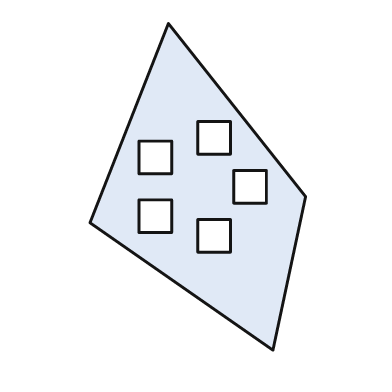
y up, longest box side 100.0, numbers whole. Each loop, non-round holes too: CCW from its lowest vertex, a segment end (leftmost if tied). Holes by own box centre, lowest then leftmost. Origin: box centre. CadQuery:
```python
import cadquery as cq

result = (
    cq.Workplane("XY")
    .moveTo(23.0, -50.0)
    .lineTo(33.0, -3.0)
    .lineTo(-9.0, 50.0)
    .lineTo(-33.0, -11.0)
    .close()
    .moveTo(0.0, -20.0)
    .lineTo(10.0, -20.0)
    .lineTo(10.0, -10.0)
    .lineTo(0.0, -10.0)
    .close()
    .moveTo(-18.0, -14.0)
    .lineTo(-8.0, -14.0)
    .lineTo(-8.0, -4.0)
    .lineTo(-18.0, -4.0)
    .close()
    .moveTo(11.0, -5.0)
    .lineTo(21.0, -5.0)
    .lineTo(21.0, 5.0)
    .lineTo(11.0, 5.0)
    .close()
    .moveTo(-18.0, 4.0)
    .lineTo(-8.0, 4.0)
    .lineTo(-8.0, 14.0)
    .lineTo(-18.0, 14.0)
    .close()
    .moveTo(0.0, 10.0)
    .lineTo(10.0, 10.0)
    .lineTo(10.0, 20.0)
    .lineTo(0.0, 20.0)
    .close()
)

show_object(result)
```